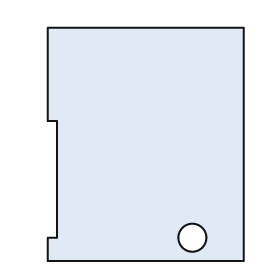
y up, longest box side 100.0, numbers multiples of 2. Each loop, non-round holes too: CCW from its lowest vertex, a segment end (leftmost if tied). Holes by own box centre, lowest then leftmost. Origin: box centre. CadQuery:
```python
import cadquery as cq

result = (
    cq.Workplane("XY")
    .moveTo(-42.0, -50.0)
    .lineTo(42.0, -50.0)
    .lineTo(42.0, 50.0)
    .lineTo(-42.0, 50.0)
    .lineTo(-42.0, 10.0)
    .lineTo(-38.0, 10.0)
    .lineTo(-38.0, -40.0)
    .lineTo(-42.0, -40.0)
    .close()
    .moveTo(20.0, -40.0)
    .circle(6.0)
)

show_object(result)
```